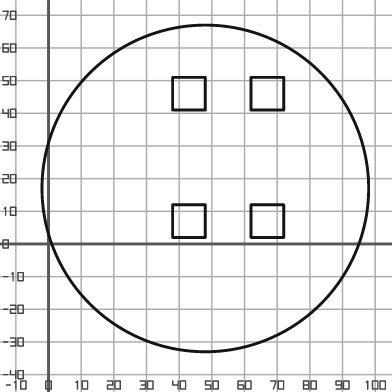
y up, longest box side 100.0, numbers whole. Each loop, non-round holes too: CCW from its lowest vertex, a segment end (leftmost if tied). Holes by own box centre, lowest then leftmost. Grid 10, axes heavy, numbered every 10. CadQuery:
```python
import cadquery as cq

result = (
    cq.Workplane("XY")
    .moveTo(48.0, 17.0)
    .circle(50.0)
    .moveTo(38.0, 2.0)
    .lineTo(48.0, 2.0)
    .lineTo(48.0, 12.0)
    .lineTo(38.0, 12.0)
    .close()
    .moveTo(62.0, 2.0)
    .lineTo(72.0, 2.0)
    .lineTo(72.0, 12.0)
    .lineTo(62.0, 12.0)
    .close()
    .moveTo(38.0, 41.0)
    .lineTo(48.0, 41.0)
    .lineTo(48.0, 51.0)
    .lineTo(38.0, 51.0)
    .close()
    .moveTo(62.0, 41.0)
    .lineTo(72.0, 41.0)
    .lineTo(72.0, 51.0)
    .lineTo(62.0, 51.0)
    .close()
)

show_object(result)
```